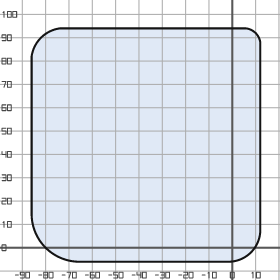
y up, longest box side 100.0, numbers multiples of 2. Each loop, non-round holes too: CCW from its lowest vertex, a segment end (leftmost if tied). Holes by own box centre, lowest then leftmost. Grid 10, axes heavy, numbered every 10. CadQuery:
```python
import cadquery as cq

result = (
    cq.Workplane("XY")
    .moveTo(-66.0, -6.0)
    .lineTo(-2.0, -6.0)
    .threePointArc((8.0, -2.0), (12.0, 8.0))
    .lineTo(12.0, 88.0)
    .threePointArc((10.0, 92.0), (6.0, 94.0))
    .lineTo(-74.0, 94.0)
    .threePointArc((-82.0, 90.0), (-86.0, 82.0))
    .lineTo(-86.0, 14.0)
    .threePointArc((-80.0, 0.0), (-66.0, -6.0))
    .close()
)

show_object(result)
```